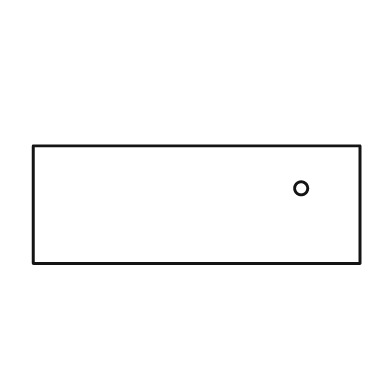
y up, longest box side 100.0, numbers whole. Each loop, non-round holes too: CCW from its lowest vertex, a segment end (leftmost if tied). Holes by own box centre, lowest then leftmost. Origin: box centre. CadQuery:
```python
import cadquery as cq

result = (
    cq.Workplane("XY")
    .moveTo(-50.0, -18.0)
    .lineTo(50.0, -18.0)
    .lineTo(50.0, 18.0)
    .lineTo(-50.0, 18.0)
    .close()
    .moveTo(32.0, 5.0)
    .circle(2.0)
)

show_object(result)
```